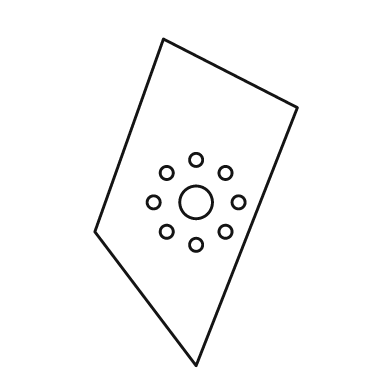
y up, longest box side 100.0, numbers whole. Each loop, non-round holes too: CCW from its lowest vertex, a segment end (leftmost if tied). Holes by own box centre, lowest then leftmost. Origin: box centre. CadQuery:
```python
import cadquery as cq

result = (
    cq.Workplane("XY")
    .moveTo(0.0, -50.0)
    .lineTo(31.0, 29.0)
    .lineTo(-10.0, 50.0)
    .lineTo(-31.0, -9.0)
    .close()
    .moveTo(0.0, -13.0)
    .circle(2.0)
    .moveTo(-9.0, -9.0)
    .circle(2.0)
    .moveTo(9.0, -9.0)
    .circle(2.0)
    .moveTo(-13.0, 0.0)
    .circle(2.0)
    .moveTo(0.0, 0.0)
    .circle(5.0)
    .moveTo(13.0, 0.0)
    .circle(2.0)
    .moveTo(-9.0, 9.0)
    .circle(2.0)
    .moveTo(9.0, 9.0)
    .circle(2.0)
    .moveTo(0.0, 13.0)
    .circle(2.0)
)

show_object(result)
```